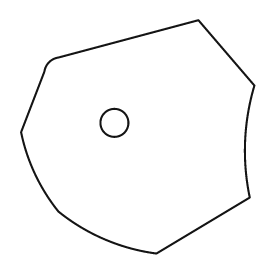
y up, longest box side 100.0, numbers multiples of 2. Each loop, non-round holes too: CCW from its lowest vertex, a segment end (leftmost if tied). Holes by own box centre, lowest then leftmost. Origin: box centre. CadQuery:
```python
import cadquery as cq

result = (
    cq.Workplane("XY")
    .moveTo(8.0, -50.0)
    .lineTo(48.0, -26.0)
    .threePointArc((46.0, -2.0), (50.0, 22.0))
    .lineTo(26.0, 50.0)
    .lineTo(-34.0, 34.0)
    .threePointArc((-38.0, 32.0), (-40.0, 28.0))
    .lineTo(-50.0, 2.0)
    .threePointArc((-44.0, -16.0), (-34.0, -32.0))
    .threePointArc((-14.0, -44.0), (8.0, -50.0))
    .close()
    .moveTo(-10.0, 6.0)
    .circle(6.0)
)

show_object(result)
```